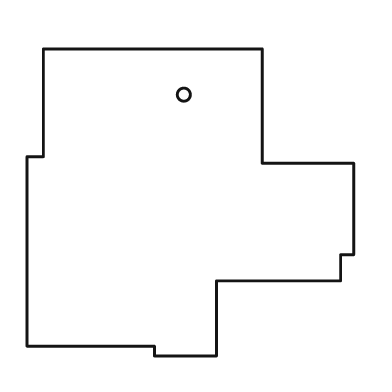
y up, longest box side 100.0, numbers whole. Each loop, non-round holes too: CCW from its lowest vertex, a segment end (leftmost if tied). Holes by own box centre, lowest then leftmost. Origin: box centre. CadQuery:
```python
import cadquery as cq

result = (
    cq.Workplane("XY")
    .moveTo(-11.0, -47.0)
    .lineTo(8.0, -47.0)
    .lineTo(8.0, -24.0)
    .lineTo(46.0, -24.0)
    .lineTo(46.0, -16.0)
    .lineTo(50.0, -16.0)
    .lineTo(50.0, 12.0)
    .lineTo(22.0, 12.0)
    .lineTo(22.0, 47.0)
    .lineTo(-45.0, 47.0)
    .lineTo(-45.0, 14.0)
    .lineTo(-50.0, 14.0)
    .lineTo(-50.0, -44.0)
    .lineTo(-11.0, -44.0)
    .close()
    .moveTo(-2.0, 33.0)
    .circle(2.0)
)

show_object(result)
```